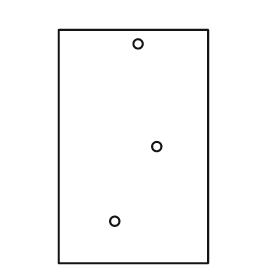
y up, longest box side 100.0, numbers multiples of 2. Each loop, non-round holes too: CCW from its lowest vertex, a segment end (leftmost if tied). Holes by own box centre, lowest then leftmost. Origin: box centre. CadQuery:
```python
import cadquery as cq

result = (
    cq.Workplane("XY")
    .moveTo(-32.0, -50.0)
    .lineTo(32.0, -50.0)
    .lineTo(32.0, 50.0)
    .lineTo(-32.0, 50.0)
    .close()
    .moveTo(-8.0, -32.0)
    .circle(2.0)
    .moveTo(10.0, 0.0)
    .circle(2.0)
    .moveTo(2.0, 44.0)
    .circle(2.0)
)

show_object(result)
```